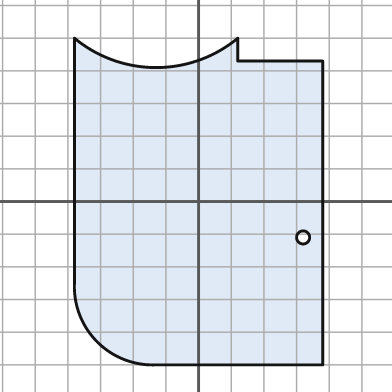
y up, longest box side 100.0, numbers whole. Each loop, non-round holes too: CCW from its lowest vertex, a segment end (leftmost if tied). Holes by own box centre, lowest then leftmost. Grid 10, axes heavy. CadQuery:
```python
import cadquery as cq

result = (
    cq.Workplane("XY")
    .moveTo(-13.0, -50.0)
    .lineTo(38.0, -50.0)
    .lineTo(38.0, 43.0)
    .lineTo(12.0, 43.0)
    .lineTo(12.0, 50.0)
    .threePointArc((-13.0, 41.0), (-38.0, 50.0))
    .lineTo(-38.0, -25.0)
    .threePointArc((-31.0, -43.0), (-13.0, -50.0))
    .close()
    .moveTo(32.0, -11.0)
    .circle(2.0)
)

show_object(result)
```